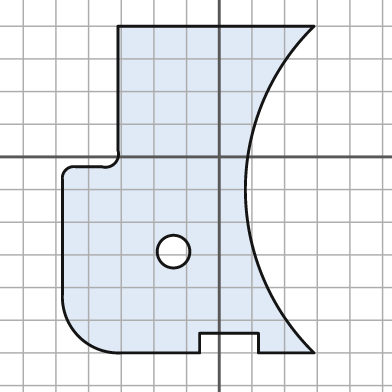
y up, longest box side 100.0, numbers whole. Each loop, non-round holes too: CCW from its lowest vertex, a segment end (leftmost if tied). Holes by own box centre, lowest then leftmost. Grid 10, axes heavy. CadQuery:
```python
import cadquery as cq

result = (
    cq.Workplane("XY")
    .moveTo(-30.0, -60.0)
    .lineTo(-6.0, -60.0)
    .lineTo(-6.0, -54.0)
    .lineTo(12.0, -54.0)
    .lineTo(12.0, -60.0)
    .lineTo(29.0, -60.0)
    .threePointArc((8.0, -10.0), (29.0, 40.0))
    .lineTo(-31.0, 40.0)
    .lineTo(-31.0, 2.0)
    .threePointArc((-32.0, -2.0), (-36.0, -3.0))
    .lineTo(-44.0, -3.0)
    .threePointArc((-47.0, -4.0), (-48.0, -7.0))
    .lineTo(-48.0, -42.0)
    .threePointArc((-43.0, -55.0), (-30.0, -60.0))
    .close()
    .moveTo(-14.0, -29.0)
    .circle(5.0)
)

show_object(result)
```